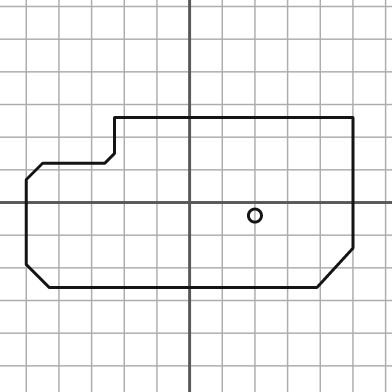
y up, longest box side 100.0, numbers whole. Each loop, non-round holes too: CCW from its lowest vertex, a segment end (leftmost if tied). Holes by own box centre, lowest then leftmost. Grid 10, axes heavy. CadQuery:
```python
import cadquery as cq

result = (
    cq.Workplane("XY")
    .moveTo(-43.0, -26.0)
    .lineTo(39.0, -26.0)
    .lineTo(50.0, -14.0)
    .lineTo(50.0, 26.0)
    .lineTo(-23.0, 26.0)
    .lineTo(-23.0, 15.0)
    .lineTo(-26.0, 12.0)
    .lineTo(-45.0, 12.0)
    .lineTo(-50.0, 7.0)
    .lineTo(-50.0, -19.0)
    .close()
    .moveTo(20.0, -4.0)
    .circle(2.0)
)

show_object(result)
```